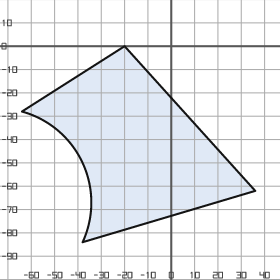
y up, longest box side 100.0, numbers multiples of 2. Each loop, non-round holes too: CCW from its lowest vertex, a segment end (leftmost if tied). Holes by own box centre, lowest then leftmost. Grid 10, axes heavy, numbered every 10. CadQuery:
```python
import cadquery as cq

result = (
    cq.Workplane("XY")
    .moveTo(-38.0, -84.0)
    .lineTo(36.0, -62.0)
    .lineTo(-20.0, 0.0)
    .lineTo(-64.0, -28.0)
    .threePointArc((-38.0, -50.0), (-38.0, -84.0))
    .close()
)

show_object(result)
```